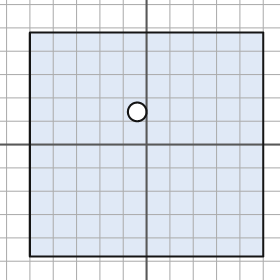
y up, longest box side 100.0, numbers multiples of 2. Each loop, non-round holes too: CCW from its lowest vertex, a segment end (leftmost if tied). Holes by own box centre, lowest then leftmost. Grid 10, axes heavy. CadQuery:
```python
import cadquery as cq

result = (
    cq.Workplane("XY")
    .moveTo(-50.0, -48.0)
    .lineTo(50.0, -48.0)
    .lineTo(50.0, 48.0)
    .lineTo(-50.0, 48.0)
    .close()
    .moveTo(-4.0, 14.0)
    .circle(4.0)
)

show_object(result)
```